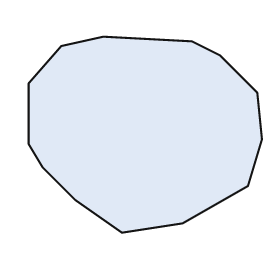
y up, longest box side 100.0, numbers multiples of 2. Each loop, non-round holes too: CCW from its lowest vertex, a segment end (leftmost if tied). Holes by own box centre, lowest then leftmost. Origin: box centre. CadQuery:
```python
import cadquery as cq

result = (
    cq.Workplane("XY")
    .moveTo(-10.0, -42.0)
    .lineTo(16.0, -38.0)
    .lineTo(44.0, -22.0)
    .lineTo(50.0, -2.0)
    .lineTo(48.0, 18.0)
    .lineTo(32.0, 34.0)
    .lineTo(20.0, 40.0)
    .lineTo(-18.0, 42.0)
    .lineTo(-36.0, 38.0)
    .lineTo(-50.0, 22.0)
    .lineTo(-50.0, -4.0)
    .lineTo(-44.0, -14.0)
    .lineTo(-30.0, -28.0)
    .close()
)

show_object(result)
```